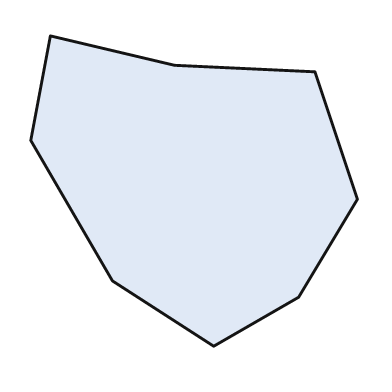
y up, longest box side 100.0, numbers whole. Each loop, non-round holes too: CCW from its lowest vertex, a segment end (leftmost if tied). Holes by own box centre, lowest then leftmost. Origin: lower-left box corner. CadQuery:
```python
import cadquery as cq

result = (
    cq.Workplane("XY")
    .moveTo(56.0, 0.0)
    .lineTo(82.0, 15.0)
    .lineTo(100.0, 45.0)
    .lineTo(87.0, 84.0)
    .lineTo(44.0, 86.0)
    .lineTo(6.0, 95.0)
    .lineTo(0.0, 63.0)
    .lineTo(25.0, 20.0)
    .close()
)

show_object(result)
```